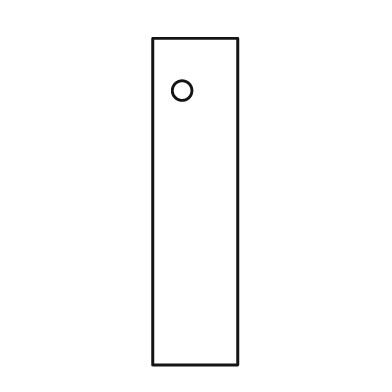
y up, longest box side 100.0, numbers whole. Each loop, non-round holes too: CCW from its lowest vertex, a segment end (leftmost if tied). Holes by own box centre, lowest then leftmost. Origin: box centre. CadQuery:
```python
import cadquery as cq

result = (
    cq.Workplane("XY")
    .moveTo(-13.0, -50.0)
    .lineTo(13.0, -50.0)
    .lineTo(13.0, 50.0)
    .lineTo(-13.0, 50.0)
    .close()
    .moveTo(-4.0, 34.0)
    .circle(3.0)
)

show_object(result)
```